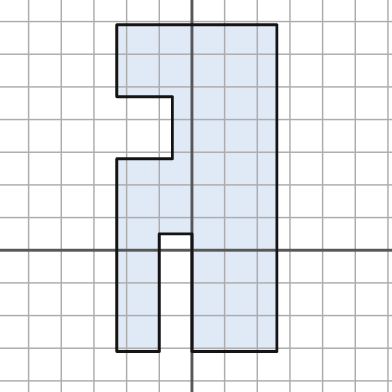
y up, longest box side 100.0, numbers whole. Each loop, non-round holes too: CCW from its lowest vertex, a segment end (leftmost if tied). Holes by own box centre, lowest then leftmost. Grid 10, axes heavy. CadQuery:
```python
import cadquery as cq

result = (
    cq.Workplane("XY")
    .moveTo(-23.0, -31.0)
    .lineTo(-10.0, -31.0)
    .lineTo(-10.0, 5.0)
    .lineTo(0.0, 5.0)
    .lineTo(0.0, -31.0)
    .lineTo(26.0, -31.0)
    .lineTo(26.0, 69.0)
    .lineTo(-23.0, 69.0)
    .lineTo(-23.0, 47.0)
    .lineTo(-6.0, 47.0)
    .lineTo(-6.0, 28.0)
    .lineTo(-23.0, 28.0)
    .close()
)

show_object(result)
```